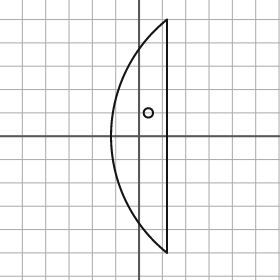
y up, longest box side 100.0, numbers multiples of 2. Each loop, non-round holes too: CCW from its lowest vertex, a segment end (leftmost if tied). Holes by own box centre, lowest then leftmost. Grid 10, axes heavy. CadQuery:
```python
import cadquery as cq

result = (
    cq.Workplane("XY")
    .moveTo(12.0, -50.0)
    .lineTo(12.0, 50.0)
    .threePointArc((-12.0, 0.0), (12.0, -50.0))
    .close()
    .moveTo(4.0, 10.0)
    .circle(2.0)
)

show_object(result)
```